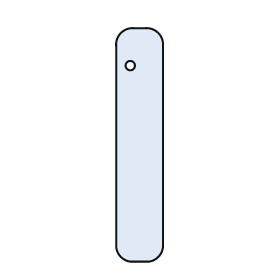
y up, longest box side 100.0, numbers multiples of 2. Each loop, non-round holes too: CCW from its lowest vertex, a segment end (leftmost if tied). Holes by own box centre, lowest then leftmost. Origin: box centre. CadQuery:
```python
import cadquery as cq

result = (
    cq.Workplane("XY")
    .moveTo(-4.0, -50.0)
    .lineTo(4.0, -50.0)
    .threePointArc((8.0, -48.0), (10.0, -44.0))
    .lineTo(10.0, 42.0)
    .threePointArc((8.0, 48.0), (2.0, 50.0))
    .lineTo(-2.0, 50.0)
    .threePointArc((-8.0, 48.0), (-10.0, 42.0))
    .lineTo(-10.0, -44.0)
    .threePointArc((-8.0, -48.0), (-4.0, -50.0))
    .close()
    .moveTo(-4.0, 34.0)
    .circle(2.0)
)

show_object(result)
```